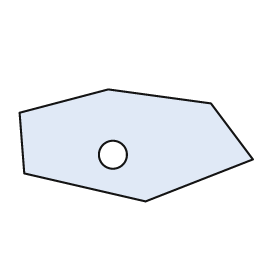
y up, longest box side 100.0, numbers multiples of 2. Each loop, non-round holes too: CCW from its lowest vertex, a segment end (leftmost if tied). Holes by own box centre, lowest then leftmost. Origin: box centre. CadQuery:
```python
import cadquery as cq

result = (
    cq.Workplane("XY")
    .moveTo(4.0, -24.0)
    .lineTo(50.0, -6.0)
    .lineTo(32.0, 18.0)
    .lineTo(-12.0, 24.0)
    .lineTo(-50.0, 14.0)
    .lineTo(-48.0, -12.0)
    .close()
    .moveTo(-10.0, -4.0)
    .circle(6.0)
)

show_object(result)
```